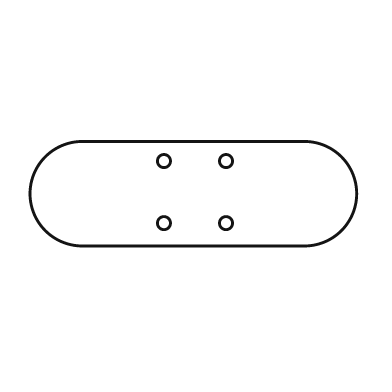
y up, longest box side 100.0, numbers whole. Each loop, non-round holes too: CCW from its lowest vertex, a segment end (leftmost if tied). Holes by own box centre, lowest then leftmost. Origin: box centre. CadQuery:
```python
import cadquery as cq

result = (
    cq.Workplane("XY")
    .moveTo(-34.0, -16.0)
    .lineTo(34.0, -16.0)
    .threePointArc((50.0, 0.0), (34.0, 16.0))
    .lineTo(-34.0, 16.0)
    .threePointArc((-50.0, 0.0), (-34.0, -16.0))
    .close()
    .moveTo(-9.0, -9.0)
    .circle(2.0)
    .moveTo(10.0, -9.0)
    .circle(2.0)
    .moveTo(-9.0, 10.0)
    .circle(2.0)
    .moveTo(10.0, 10.0)
    .circle(2.0)
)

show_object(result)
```